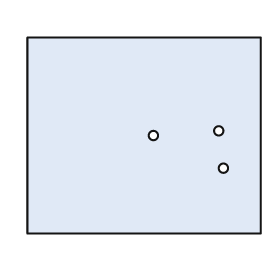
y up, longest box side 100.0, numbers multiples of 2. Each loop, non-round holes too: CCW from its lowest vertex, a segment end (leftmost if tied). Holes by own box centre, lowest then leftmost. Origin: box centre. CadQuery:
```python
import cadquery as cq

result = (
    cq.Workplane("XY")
    .moveTo(-50.0, -42.0)
    .lineTo(50.0, -42.0)
    .lineTo(50.0, 42.0)
    .lineTo(-50.0, 42.0)
    .close()
    .moveTo(34.0, -14.0)
    .circle(2.0)
    .moveTo(4.0, 0.0)
    .circle(2.0)
    .moveTo(32.0, 2.0)
    .circle(2.0)
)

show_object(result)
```